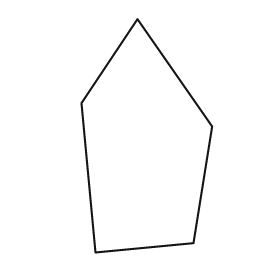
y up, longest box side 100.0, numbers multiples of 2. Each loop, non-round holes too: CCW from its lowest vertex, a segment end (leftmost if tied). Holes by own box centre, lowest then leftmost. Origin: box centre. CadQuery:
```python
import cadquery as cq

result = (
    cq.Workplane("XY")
    .moveTo(-22.0, -50.0)
    .lineTo(20.0, -46.0)
    .lineTo(28.0, 4.0)
    .lineTo(-4.0, 50.0)
    .lineTo(-28.0, 14.0)
    .close()
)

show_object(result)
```